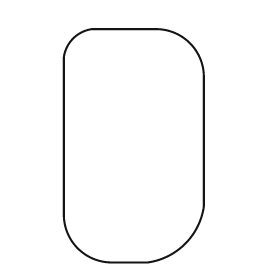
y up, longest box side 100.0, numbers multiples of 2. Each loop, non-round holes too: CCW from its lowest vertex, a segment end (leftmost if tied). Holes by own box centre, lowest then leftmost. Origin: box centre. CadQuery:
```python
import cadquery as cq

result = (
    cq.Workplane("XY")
    .moveTo(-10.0, -50.0)
    .lineTo(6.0, -50.0)
    .threePointArc((22.0, -42.0), (30.0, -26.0))
    .lineTo(30.0, 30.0)
    .threePointArc((24.0, 44.0), (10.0, 50.0))
    .lineTo(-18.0, 50.0)
    .threePointArc((-26.0, 46.0), (-30.0, 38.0))
    .lineTo(-30.0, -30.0)
    .threePointArc((-24.0, -44.0), (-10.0, -50.0))
    .close()
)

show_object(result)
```